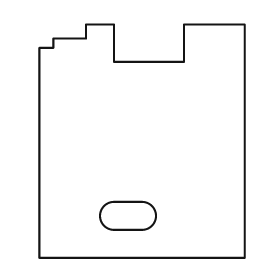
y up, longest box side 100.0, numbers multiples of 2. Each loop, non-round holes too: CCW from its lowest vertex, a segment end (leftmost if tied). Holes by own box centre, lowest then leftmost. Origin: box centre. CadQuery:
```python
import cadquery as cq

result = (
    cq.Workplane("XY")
    .moveTo(-44.0, -50.0)
    .lineTo(44.0, -50.0)
    .lineTo(44.0, 50.0)
    .lineTo(18.0, 50.0)
    .lineTo(18.0, 34.0)
    .lineTo(-12.0, 34.0)
    .lineTo(-12.0, 50.0)
    .lineTo(-24.0, 50.0)
    .lineTo(-24.0, 44.0)
    .lineTo(-38.0, 44.0)
    .lineTo(-38.0, 40.0)
    .lineTo(-44.0, 40.0)
    .close()
    .moveTo(-12.0, -38.0)
    .lineTo(0.0, -38.0)
    .threePointArc((6.0, -32.0), (0.0, -26.0))
    .lineTo(-12.0, -26.0)
    .threePointArc((-18.0, -32.0), (-12.0, -38.0))
    .close()
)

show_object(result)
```